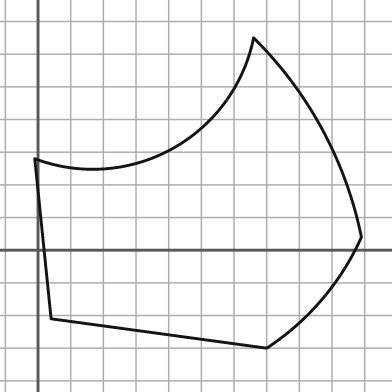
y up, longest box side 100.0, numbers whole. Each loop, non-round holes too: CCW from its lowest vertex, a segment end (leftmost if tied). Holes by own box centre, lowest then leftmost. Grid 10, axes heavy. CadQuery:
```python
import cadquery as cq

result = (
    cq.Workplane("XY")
    .moveTo(70.0, -30.0)
    .threePointArc((87.0, -15.0), (99.0, 4.0))
    .threePointArc((87.0, 37.0), (66.0, 65.0))
    .threePointArc((41.0, 31.0), (-1.0, 28.0))
    .lineTo(4.0, -21.0)
    .close()
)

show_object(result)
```